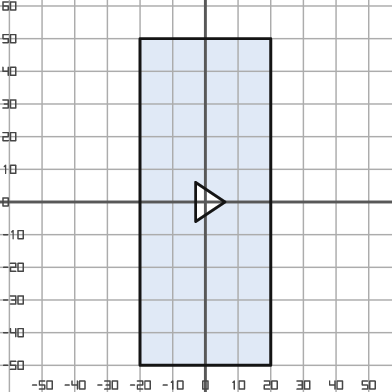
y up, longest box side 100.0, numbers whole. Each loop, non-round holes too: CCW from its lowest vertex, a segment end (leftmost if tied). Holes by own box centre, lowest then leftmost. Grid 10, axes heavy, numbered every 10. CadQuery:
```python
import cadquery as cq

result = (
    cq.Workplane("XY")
    .moveTo(-20.0, -50.0)
    .lineTo(20.0, -50.0)
    .lineTo(20.0, 50.0)
    .lineTo(-20.0, 50.0)
    .close()
    .moveTo(-3.0, -6.0)
    .lineTo(6.0, 0.0)
    .lineTo(-3.0, 6.0)
    .close()
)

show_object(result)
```